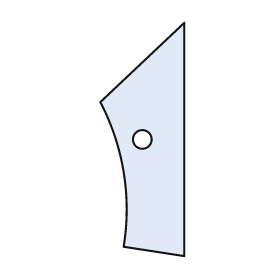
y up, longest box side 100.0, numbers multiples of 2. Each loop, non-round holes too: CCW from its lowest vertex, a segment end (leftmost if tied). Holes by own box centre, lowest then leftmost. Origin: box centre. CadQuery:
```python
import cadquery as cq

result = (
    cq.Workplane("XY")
    .moveTo(18.0, -50.0)
    .lineTo(18.0, 50.0)
    .lineTo(-18.0, 16.0)
    .threePointArc((-8.0, -14.0), (-8.0, -46.0))
    .close()
    .moveTo(0.0, 0.0)
    .circle(4.0)
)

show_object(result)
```